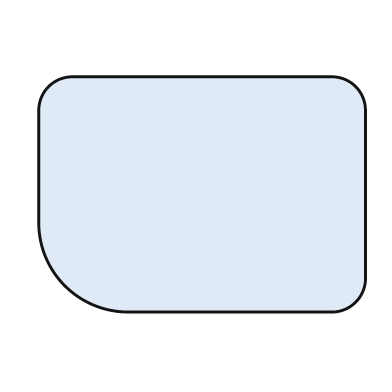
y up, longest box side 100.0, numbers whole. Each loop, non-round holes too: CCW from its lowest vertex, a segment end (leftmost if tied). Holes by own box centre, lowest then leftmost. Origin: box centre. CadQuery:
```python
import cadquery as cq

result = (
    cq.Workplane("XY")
    .moveTo(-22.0, -36.0)
    .lineTo(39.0, -36.0)
    .threePointArc((47.0, -33.0), (50.0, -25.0))
    .lineTo(50.0, 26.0)
    .threePointArc((47.0, 33.0), (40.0, 36.0))
    .lineTo(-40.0, 36.0)
    .threePointArc((-47.0, 33.0), (-50.0, 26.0))
    .lineTo(-50.0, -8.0)
    .threePointArc((-42.0, -28.0), (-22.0, -36.0))
    .close()
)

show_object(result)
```